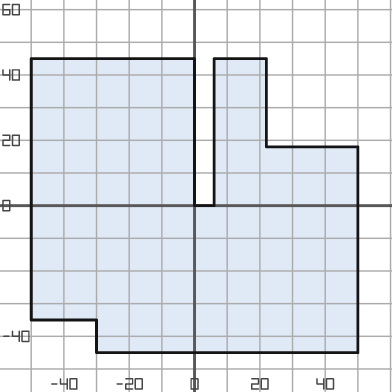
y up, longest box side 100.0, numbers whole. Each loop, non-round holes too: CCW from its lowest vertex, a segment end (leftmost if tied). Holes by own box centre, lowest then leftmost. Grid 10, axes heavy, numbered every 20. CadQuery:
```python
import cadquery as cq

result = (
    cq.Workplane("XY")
    .moveTo(-30.0, -45.0)
    .lineTo(50.0, -45.0)
    .lineTo(50.0, 18.0)
    .lineTo(22.0, 18.0)
    .lineTo(22.0, 45.0)
    .lineTo(6.0, 45.0)
    .lineTo(6.0, 0.0)
    .lineTo(0.0, 0.0)
    .lineTo(0.0, 45.0)
    .lineTo(-50.0, 45.0)
    .lineTo(-50.0, -35.0)
    .lineTo(-30.0, -35.0)
    .close()
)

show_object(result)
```